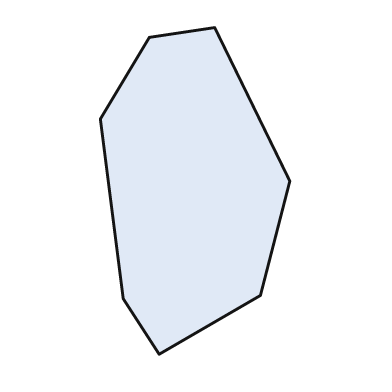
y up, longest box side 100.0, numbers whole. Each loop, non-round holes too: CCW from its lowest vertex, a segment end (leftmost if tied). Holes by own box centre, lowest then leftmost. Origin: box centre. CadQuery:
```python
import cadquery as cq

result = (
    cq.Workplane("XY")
    .moveTo(-11.0, -50.0)
    .lineTo(20.0, -32.0)
    .lineTo(29.0, 3.0)
    .lineTo(6.0, 50.0)
    .lineTo(-14.0, 47.0)
    .lineTo(-29.0, 22.0)
    .lineTo(-22.0, -33.0)
    .close()
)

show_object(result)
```